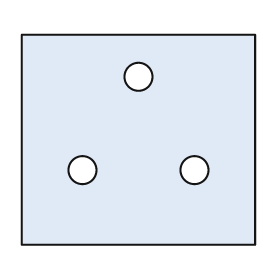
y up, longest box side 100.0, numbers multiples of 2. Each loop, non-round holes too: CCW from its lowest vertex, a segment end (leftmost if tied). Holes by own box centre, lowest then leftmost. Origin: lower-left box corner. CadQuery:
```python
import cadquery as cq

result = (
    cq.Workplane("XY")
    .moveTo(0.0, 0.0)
    .lineTo(100.0, 0.0)
    .lineTo(100.0, 90.0)
    .lineTo(0.0, 90.0)
    .close()
    .moveTo(26.0, 32.0)
    .circle(6.0)
    .moveTo(74.0, 32.0)
    .circle(6.0)
    .moveTo(50.0, 72.0)
    .circle(6.0)
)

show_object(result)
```